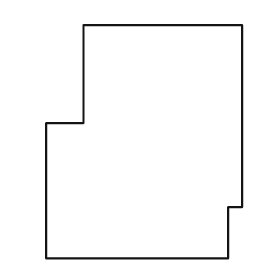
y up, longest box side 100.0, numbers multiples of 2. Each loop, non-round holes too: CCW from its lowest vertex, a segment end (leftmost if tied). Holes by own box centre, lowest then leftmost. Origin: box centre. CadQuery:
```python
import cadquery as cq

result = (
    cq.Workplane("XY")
    .moveTo(-42.0, -50.0)
    .lineTo(36.0, -50.0)
    .lineTo(36.0, -28.0)
    .lineTo(42.0, -28.0)
    .lineTo(42.0, 50.0)
    .lineTo(-26.0, 50.0)
    .lineTo(-26.0, 8.0)
    .lineTo(-42.0, 8.0)
    .close()
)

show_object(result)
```